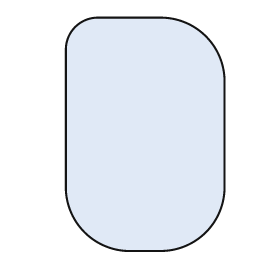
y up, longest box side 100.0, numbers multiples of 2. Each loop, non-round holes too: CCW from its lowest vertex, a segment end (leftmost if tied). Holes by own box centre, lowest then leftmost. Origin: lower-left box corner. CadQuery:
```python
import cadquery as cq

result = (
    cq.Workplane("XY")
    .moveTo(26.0, 0.0)
    .lineTo(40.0, 0.0)
    .threePointArc((60.0, 8.0), (68.0, 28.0))
    .lineTo(68.0, 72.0)
    .threePointArc((60.0, 92.0), (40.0, 100.0))
    .lineTo(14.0, 100.0)
    .threePointArc((4.0, 96.0), (0.0, 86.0))
    .lineTo(0.0, 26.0)
    .threePointArc((8.0, 8.0), (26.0, 0.0))
    .close()
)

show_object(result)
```